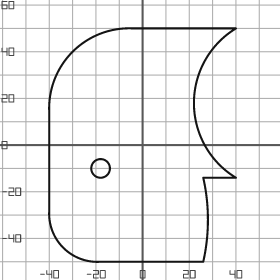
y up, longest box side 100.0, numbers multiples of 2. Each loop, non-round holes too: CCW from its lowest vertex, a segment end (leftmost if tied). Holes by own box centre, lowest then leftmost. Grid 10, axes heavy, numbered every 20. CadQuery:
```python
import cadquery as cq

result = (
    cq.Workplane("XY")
    .moveTo(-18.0, -50.0)
    .lineTo(26.0, -50.0)
    .threePointArc((28.0, -32.0), (26.0, -14.0))
    .lineTo(40.0, -14.0)
    .threePointArc((22.0, 18.0), (40.0, 50.0))
    .lineTo(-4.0, 50.0)
    .threePointArc((-30.0, 40.0), (-40.0, 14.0))
    .lineTo(-40.0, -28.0)
    .threePointArc((-34.0, -44.0), (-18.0, -50.0))
    .close()
    .moveTo(-18.0, -10.0)
    .circle(4.0)
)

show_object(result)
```